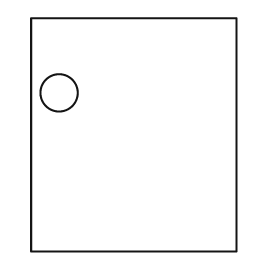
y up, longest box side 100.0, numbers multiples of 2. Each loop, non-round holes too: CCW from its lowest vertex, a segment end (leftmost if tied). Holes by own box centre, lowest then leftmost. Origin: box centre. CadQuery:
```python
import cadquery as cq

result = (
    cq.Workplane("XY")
    .moveTo(-44.0, -50.0)
    .lineTo(44.0, -50.0)
    .lineTo(44.0, 50.0)
    .lineTo(-44.0, 50.0)
    .close()
    .moveTo(-32.0, 18.0)
    .circle(8.0)
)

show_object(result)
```